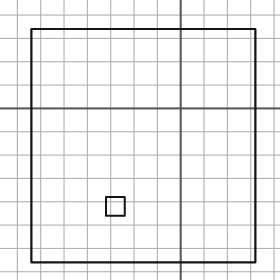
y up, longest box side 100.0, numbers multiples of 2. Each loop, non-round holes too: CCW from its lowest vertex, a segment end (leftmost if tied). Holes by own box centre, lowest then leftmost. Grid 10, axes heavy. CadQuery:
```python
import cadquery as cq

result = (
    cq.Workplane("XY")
    .moveTo(-64.0, -66.0)
    .lineTo(32.0, -66.0)
    .lineTo(32.0, 34.0)
    .lineTo(-64.0, 34.0)
    .close()
    .moveTo(-32.0, -46.0)
    .lineTo(-24.0, -46.0)
    .lineTo(-24.0, -38.0)
    .lineTo(-32.0, -38.0)
    .close()
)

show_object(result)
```